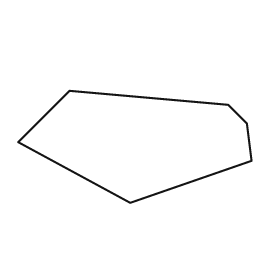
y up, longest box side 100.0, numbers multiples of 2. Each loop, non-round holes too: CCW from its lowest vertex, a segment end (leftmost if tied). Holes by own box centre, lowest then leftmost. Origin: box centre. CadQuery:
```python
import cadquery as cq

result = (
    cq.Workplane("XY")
    .moveTo(-2.0, -24.0)
    .lineTo(50.0, -6.0)
    .lineTo(48.0, 10.0)
    .lineTo(40.0, 18.0)
    .lineTo(-28.0, 24.0)
    .lineTo(-50.0, 2.0)
    .close()
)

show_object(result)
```